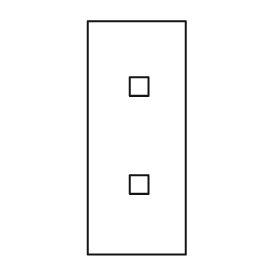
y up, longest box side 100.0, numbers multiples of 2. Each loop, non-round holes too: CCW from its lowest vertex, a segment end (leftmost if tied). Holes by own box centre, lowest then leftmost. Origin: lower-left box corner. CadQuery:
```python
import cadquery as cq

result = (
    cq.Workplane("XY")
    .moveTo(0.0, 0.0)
    .lineTo(42.0, 0.0)
    .lineTo(42.0, 100.0)
    .lineTo(0.0, 100.0)
    .close()
    .moveTo(18.0, 26.0)
    .lineTo(26.0, 26.0)
    .lineTo(26.0, 34.0)
    .lineTo(18.0, 34.0)
    .close()
    .moveTo(18.0, 68.0)
    .lineTo(26.0, 68.0)
    .lineTo(26.0, 76.0)
    .lineTo(18.0, 76.0)
    .close()
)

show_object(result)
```